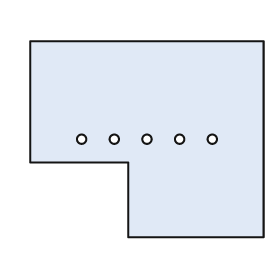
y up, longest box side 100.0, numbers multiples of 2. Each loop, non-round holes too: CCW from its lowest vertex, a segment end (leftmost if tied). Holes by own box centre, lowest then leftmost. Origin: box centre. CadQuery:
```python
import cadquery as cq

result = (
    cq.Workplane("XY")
    .moveTo(-8.0, -42.0)
    .lineTo(50.0, -42.0)
    .lineTo(50.0, 42.0)
    .lineTo(-50.0, 42.0)
    .lineTo(-50.0, -10.0)
    .lineTo(-8.0, -10.0)
    .close()
    .moveTo(-28.0, 0.0)
    .circle(2.0)
    .moveTo(-14.0, 0.0)
    .circle(2.0)
    .moveTo(0.0, 0.0)
    .circle(2.0)
    .moveTo(14.0, 0.0)
    .circle(2.0)
    .moveTo(28.0, 0.0)
    .circle(2.0)
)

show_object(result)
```